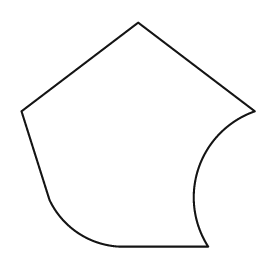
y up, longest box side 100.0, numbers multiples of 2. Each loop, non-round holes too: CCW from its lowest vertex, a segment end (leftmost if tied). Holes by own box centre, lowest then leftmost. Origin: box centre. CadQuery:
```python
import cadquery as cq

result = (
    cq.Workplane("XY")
    .moveTo(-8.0, -48.0)
    .lineTo(30.0, -48.0)
    .threePointArc((26.0, -14.0), (50.0, 10.0))
    .lineTo(0.0, 48.0)
    .lineTo(-50.0, 10.0)
    .lineTo(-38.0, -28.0)
    .threePointArc((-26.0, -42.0), (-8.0, -48.0))
    .close()
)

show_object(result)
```